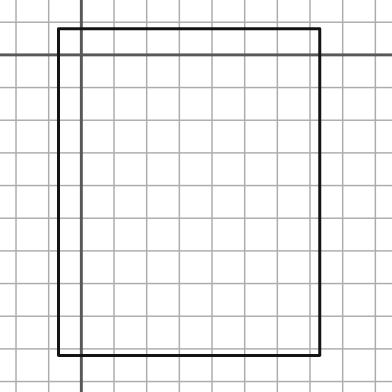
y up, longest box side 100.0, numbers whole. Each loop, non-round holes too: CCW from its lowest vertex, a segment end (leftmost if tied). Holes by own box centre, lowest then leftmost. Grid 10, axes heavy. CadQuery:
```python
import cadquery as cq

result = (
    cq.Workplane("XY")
    .moveTo(-7.0, -92.0)
    .lineTo(73.0, -92.0)
    .lineTo(73.0, 8.0)
    .lineTo(-7.0, 8.0)
    .close()
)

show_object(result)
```